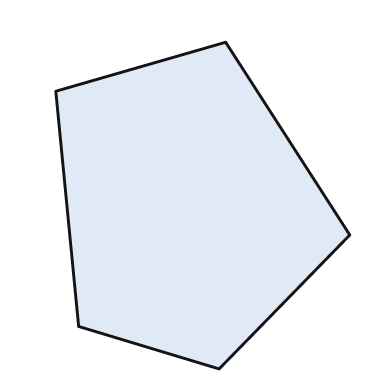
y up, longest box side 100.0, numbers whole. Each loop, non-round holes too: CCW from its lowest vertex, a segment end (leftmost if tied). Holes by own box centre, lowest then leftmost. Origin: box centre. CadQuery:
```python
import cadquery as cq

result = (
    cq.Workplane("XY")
    .moveTo(5.0, -50.0)
    .lineTo(45.0, -9.0)
    .lineTo(7.0, 50.0)
    .lineTo(-45.0, 35.0)
    .lineTo(-38.0, -37.0)
    .close()
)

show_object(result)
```